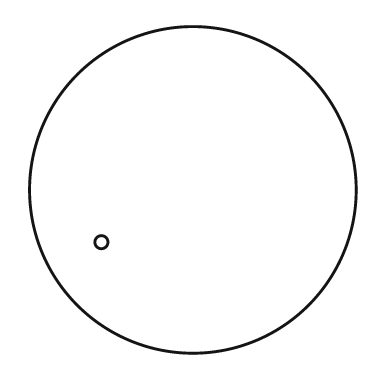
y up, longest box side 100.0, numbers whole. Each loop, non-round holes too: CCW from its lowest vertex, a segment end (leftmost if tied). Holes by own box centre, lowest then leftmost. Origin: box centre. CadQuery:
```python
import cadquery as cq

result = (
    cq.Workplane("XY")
    .moveTo(0.0, 0.0)
    .circle(50.0)
    .moveTo(-28.0, -16.0)
    .circle(2.0)
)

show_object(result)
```